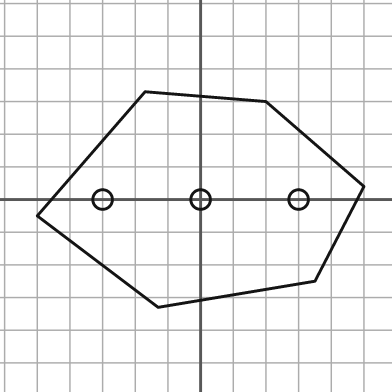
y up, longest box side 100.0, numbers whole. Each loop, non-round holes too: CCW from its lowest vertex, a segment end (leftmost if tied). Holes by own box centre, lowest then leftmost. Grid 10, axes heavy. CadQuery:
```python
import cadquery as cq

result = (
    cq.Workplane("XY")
    .moveTo(-13.0, -33.0)
    .lineTo(35.0, -25.0)
    .lineTo(50.0, 4.0)
    .lineTo(20.0, 30.0)
    .lineTo(-17.0, 33.0)
    .lineTo(-50.0, -5.0)
    .close()
    .moveTo(-30.0, 0.0)
    .circle(3.0)
    .moveTo(0.0, 0.0)
    .circle(3.0)
    .moveTo(30.0, 0.0)
    .circle(3.0)
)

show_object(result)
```